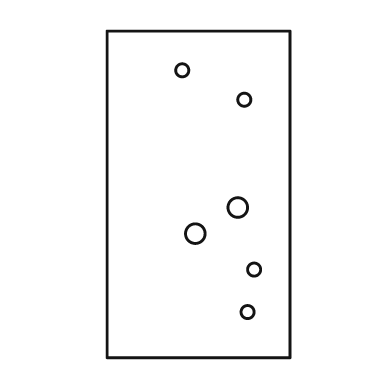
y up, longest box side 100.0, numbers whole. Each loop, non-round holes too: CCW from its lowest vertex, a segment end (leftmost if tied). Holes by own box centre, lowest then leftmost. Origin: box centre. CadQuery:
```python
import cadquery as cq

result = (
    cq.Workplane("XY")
    .moveTo(-28.0, -50.0)
    .lineTo(28.0, -50.0)
    .lineTo(28.0, 50.0)
    .lineTo(-28.0, 50.0)
    .close()
    .moveTo(15.0, -36.0)
    .circle(2.0)
    .moveTo(17.0, -23.0)
    .circle(2.0)
    .moveTo(-1.0, -12.0)
    .circle(3.0)
    .moveTo(12.0, -4.0)
    .circle(3.0)
    .moveTo(14.0, 29.0)
    .circle(2.0)
    .moveTo(-5.0, 38.0)
    .circle(2.0)
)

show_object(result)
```